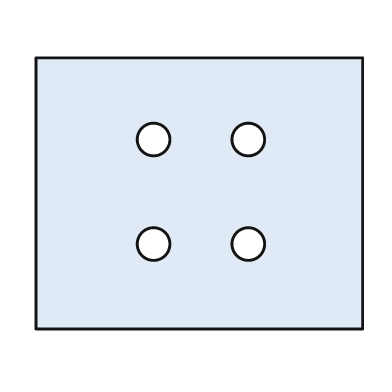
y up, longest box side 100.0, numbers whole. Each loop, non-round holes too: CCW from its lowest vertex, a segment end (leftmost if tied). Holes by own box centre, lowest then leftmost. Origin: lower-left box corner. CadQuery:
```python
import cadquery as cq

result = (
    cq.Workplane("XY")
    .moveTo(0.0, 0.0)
    .lineTo(100.0, 0.0)
    .lineTo(100.0, 83.0)
    .lineTo(0.0, 83.0)
    .close()
    .moveTo(36.0, 26.0)
    .circle(5.0)
    .moveTo(65.0, 26.0)
    .circle(5.0)
    .moveTo(36.0, 58.0)
    .circle(5.0)
    .moveTo(65.0, 58.0)
    .circle(5.0)
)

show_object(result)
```